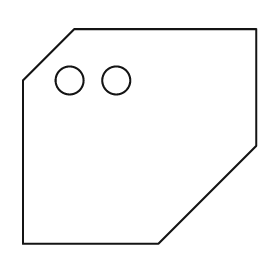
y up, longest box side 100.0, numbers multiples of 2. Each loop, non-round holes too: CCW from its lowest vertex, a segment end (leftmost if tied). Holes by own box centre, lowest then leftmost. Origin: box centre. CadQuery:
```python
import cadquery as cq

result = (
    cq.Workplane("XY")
    .moveTo(-50.0, -46.0)
    .lineTo(8.0, -46.0)
    .lineTo(50.0, -4.0)
    .lineTo(50.0, 46.0)
    .lineTo(-28.0, 46.0)
    .lineTo(-50.0, 24.0)
    .close()
    .moveTo(-30.0, 24.0)
    .circle(6.0)
    .moveTo(-10.0, 24.0)
    .circle(6.0)
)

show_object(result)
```